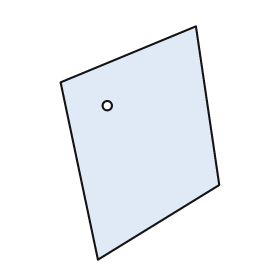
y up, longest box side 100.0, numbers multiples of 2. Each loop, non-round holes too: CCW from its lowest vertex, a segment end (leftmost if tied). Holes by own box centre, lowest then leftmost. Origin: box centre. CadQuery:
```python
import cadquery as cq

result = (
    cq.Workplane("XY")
    .moveTo(-18.0, -50.0)
    .lineTo(34.0, -18.0)
    .lineTo(24.0, 50.0)
    .lineTo(-34.0, 26.0)
    .close()
    .moveTo(-14.0, 16.0)
    .circle(2.0)
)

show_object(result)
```